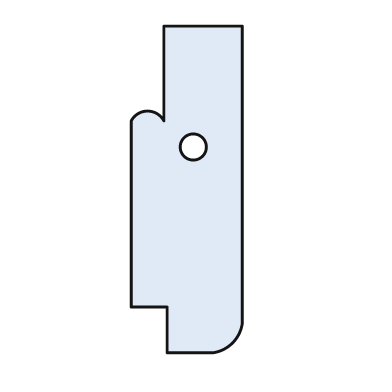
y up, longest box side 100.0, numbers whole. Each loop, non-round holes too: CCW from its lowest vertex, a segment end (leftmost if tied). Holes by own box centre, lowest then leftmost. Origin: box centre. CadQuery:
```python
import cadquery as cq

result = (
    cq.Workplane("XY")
    .moveTo(-6.0, -50.0)
    .lineTo(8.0, -50.0)
    .threePointArc((14.0, -47.0), (17.0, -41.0))
    .lineTo(17.0, 50.0)
    .lineTo(-7.0, 50.0)
    .lineTo(-7.0, 21.0)
    .threePointArc((-12.0, 24.0), (-17.0, 21.0))
    .lineTo(-17.0, -36.0)
    .lineTo(-6.0, -36.0)
    .close()
    .moveTo(2.0, 13.0)
    .circle(4.0)
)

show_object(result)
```